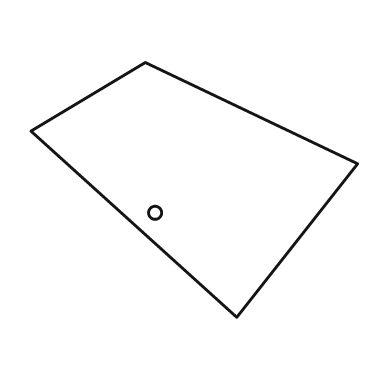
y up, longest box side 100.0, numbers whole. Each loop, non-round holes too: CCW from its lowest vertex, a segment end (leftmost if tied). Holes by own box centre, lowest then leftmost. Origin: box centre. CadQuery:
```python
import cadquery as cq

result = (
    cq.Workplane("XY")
    .moveTo(13.0, -39.0)
    .lineTo(50.0, 8.0)
    .lineTo(-15.0, 39.0)
    .lineTo(-50.0, 18.0)
    .close()
    .moveTo(-12.0, -7.0)
    .circle(2.0)
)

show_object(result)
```